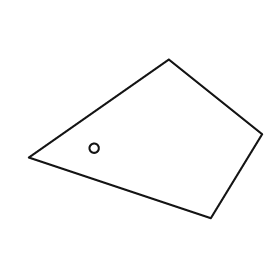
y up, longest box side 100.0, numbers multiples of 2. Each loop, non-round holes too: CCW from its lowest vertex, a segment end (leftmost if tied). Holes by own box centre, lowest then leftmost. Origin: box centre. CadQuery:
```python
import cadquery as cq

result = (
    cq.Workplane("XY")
    .moveTo(28.0, -34.0)
    .lineTo(50.0, 2.0)
    .lineTo(10.0, 34.0)
    .lineTo(-50.0, -8.0)
    .close()
    .moveTo(-22.0, -4.0)
    .circle(2.0)
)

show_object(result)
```